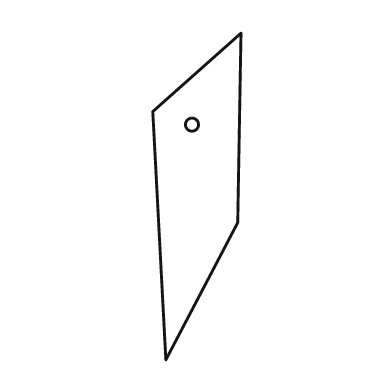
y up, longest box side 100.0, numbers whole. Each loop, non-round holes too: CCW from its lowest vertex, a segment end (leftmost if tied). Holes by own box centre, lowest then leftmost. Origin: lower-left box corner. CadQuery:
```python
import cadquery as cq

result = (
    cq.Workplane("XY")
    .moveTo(4.0, 0.0)
    .lineTo(26.0, 42.0)
    .lineTo(27.0, 100.0)
    .lineTo(0.0, 76.0)
    .close()
    .moveTo(12.0, 72.0)
    .circle(2.0)
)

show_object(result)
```